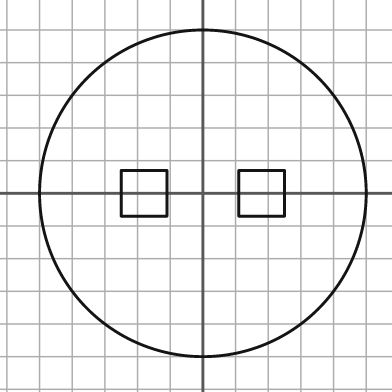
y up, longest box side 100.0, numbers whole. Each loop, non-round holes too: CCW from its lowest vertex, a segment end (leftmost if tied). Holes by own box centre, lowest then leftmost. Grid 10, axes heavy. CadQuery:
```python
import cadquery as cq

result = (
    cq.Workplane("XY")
    .moveTo(0.0, 0.0)
    .circle(50.0)
    .moveTo(-25.0, -7.0)
    .lineTo(-11.0, -7.0)
    .lineTo(-11.0, 7.0)
    .lineTo(-25.0, 7.0)
    .close()
    .moveTo(11.0, -7.0)
    .lineTo(25.0, -7.0)
    .lineTo(25.0, 7.0)
    .lineTo(11.0, 7.0)
    .close()
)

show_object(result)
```